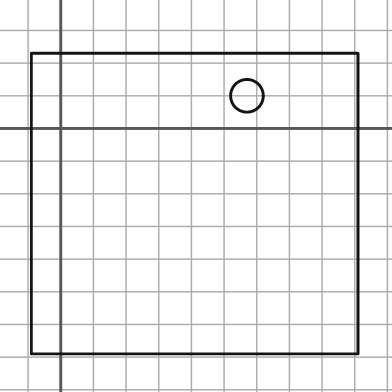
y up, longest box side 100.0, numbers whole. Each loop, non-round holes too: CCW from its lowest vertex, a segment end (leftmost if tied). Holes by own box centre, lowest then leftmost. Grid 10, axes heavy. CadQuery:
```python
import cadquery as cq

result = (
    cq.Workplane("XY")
    .moveTo(-9.0, -69.0)
    .lineTo(91.0, -69.0)
    .lineTo(91.0, 23.0)
    .lineTo(-9.0, 23.0)
    .close()
    .moveTo(57.0, 10.0)
    .circle(5.0)
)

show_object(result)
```